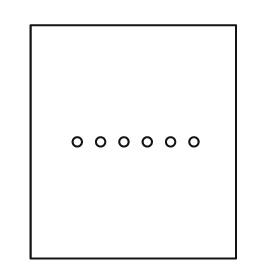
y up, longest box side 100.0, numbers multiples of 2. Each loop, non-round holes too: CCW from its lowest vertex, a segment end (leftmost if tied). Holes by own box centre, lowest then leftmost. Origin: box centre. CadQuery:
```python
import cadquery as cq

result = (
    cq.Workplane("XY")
    .moveTo(-44.0, -50.0)
    .lineTo(44.0, -50.0)
    .lineTo(44.0, 50.0)
    .lineTo(-44.0, 50.0)
    .close()
    .moveTo(-24.0, 0.0)
    .circle(2.0)
    .moveTo(-14.0, 0.0)
    .circle(2.0)
    .moveTo(-4.0, 0.0)
    .circle(2.0)
    .moveTo(6.0, 0.0)
    .circle(2.0)
    .moveTo(16.0, 0.0)
    .circle(2.0)
    .moveTo(26.0, 0.0)
    .circle(2.0)
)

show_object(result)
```